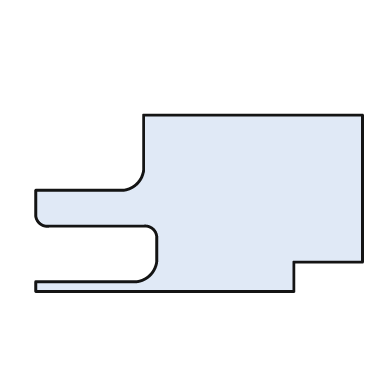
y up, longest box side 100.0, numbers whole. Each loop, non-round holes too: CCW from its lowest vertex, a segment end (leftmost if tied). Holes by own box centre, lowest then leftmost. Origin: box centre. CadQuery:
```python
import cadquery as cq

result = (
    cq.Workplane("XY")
    .moveTo(-50.0, -27.0)
    .lineTo(29.0, -27.0)
    .lineTo(29.0, -18.0)
    .lineTo(50.0, -18.0)
    .lineTo(50.0, 27.0)
    .lineTo(-17.0, 27.0)
    .lineTo(-17.0, 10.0)
    .threePointArc((-19.0, 6.0), (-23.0, 4.0))
    .lineTo(-50.0, 4.0)
    .lineTo(-50.0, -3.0)
    .threePointArc((-49.0, -6.0), (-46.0, -7.0))
    .lineTo(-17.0, -7.0)
    .threePointArc((-14.0, -8.0), (-13.0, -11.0))
    .lineTo(-13.0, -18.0)
    .threePointArc((-15.0, -22.0), (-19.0, -24.0))
    .lineTo(-50.0, -24.0)
    .close()
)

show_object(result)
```